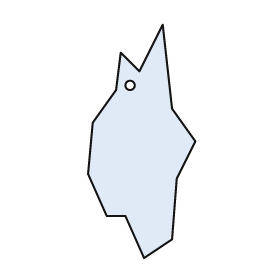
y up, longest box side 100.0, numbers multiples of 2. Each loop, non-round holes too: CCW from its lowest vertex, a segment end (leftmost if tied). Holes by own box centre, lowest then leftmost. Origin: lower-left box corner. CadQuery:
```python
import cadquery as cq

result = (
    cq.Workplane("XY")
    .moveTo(24.0, 0.0)
    .lineTo(36.0, 8.0)
    .lineTo(38.0, 34.0)
    .lineTo(46.0, 50.0)
    .lineTo(36.0, 64.0)
    .lineTo(32.0, 100.0)
    .lineTo(22.0, 80.0)
    .lineTo(14.0, 88.0)
    .lineTo(12.0, 72.0)
    .lineTo(2.0, 58.0)
    .lineTo(0.0, 36.0)
    .lineTo(8.0, 18.0)
    .lineTo(16.0, 18.0)
    .close()
    .moveTo(18.0, 74.0)
    .circle(2.0)
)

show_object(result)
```